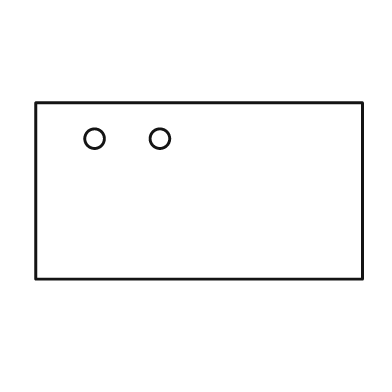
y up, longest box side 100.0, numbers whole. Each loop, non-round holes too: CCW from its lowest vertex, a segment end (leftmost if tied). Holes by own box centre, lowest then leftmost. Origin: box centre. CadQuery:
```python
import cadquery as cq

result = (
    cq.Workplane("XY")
    .moveTo(-50.0, -27.0)
    .lineTo(50.0, -27.0)
    .lineTo(50.0, 27.0)
    .lineTo(-50.0, 27.0)
    .close()
    .moveTo(-32.0, 16.0)
    .circle(3.0)
    .moveTo(-12.0, 16.0)
    .circle(3.0)
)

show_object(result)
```